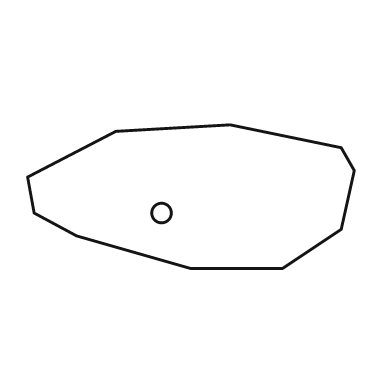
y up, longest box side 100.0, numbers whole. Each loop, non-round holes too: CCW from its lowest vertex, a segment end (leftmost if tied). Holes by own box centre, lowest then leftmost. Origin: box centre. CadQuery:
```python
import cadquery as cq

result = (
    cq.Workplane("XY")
    .moveTo(0.0, -22.0)
    .lineTo(28.0, -22.0)
    .lineTo(46.0, -10.0)
    .lineTo(50.0, 8.0)
    .lineTo(46.0, 15.0)
    .lineTo(12.0, 22.0)
    .lineTo(-23.0, 20.0)
    .lineTo(-50.0, 6.0)
    .lineTo(-48.0, -5.0)
    .lineTo(-35.0, -12.0)
    .close()
    .moveTo(-9.0, -5.0)
    .circle(3.0)
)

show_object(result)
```